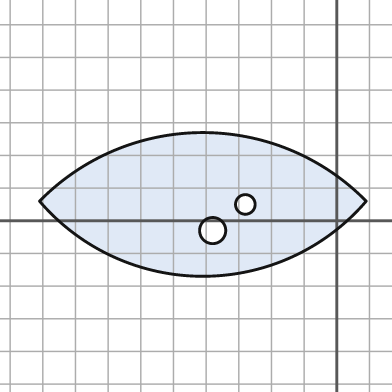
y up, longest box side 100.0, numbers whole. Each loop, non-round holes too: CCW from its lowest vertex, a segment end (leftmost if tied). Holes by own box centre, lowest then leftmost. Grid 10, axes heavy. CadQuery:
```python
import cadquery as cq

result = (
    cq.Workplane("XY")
    .moveTo(-91.0, 6.0)
    .threePointArc((-41.0, -17.0), (9.0, 6.0))
    .threePointArc((-41.0, 27.0), (-91.0, 6.0))
    .close()
    .moveTo(-38.0, -3.0)
    .circle(4.0)
    .moveTo(-28.0, 5.0)
    .circle(3.0)
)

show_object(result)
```